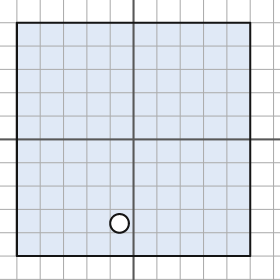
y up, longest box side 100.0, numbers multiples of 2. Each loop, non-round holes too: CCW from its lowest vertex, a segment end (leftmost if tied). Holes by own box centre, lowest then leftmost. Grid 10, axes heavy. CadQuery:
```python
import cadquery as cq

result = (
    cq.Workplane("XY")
    .moveTo(-50.0, -50.0)
    .lineTo(50.0, -50.0)
    .lineTo(50.0, 50.0)
    .lineTo(-50.0, 50.0)
    .close()
    .moveTo(-6.0, -36.0)
    .circle(4.0)
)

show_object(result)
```